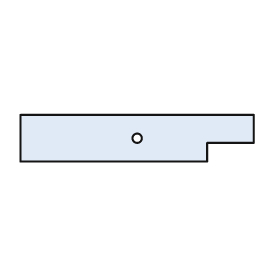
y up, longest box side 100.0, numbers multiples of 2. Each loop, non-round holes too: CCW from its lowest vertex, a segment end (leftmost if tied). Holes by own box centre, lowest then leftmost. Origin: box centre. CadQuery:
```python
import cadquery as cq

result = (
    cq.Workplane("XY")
    .moveTo(-50.0, -10.0)
    .lineTo(30.0, -10.0)
    .lineTo(30.0, -2.0)
    .lineTo(50.0, -2.0)
    .lineTo(50.0, 10.0)
    .lineTo(-50.0, 10.0)
    .close()
    .moveTo(0.0, 0.0)
    .circle(2.0)
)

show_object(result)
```